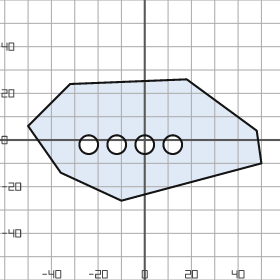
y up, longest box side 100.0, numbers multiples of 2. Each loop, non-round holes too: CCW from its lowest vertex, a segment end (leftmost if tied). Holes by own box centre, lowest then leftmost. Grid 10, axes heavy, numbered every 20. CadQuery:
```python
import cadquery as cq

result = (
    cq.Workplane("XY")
    .moveTo(-10.0, -26.0)
    .lineTo(50.0, -10.0)
    .lineTo(48.0, 4.0)
    .lineTo(18.0, 26.0)
    .lineTo(-32.0, 24.0)
    .lineTo(-50.0, 6.0)
    .lineTo(-36.0, -14.0)
    .close()
    .moveTo(-24.0, -2.0)
    .circle(4.0)
    .moveTo(-12.0, -2.0)
    .circle(4.0)
    .moveTo(0.0, -2.0)
    .circle(4.0)
    .moveTo(12.0, -2.0)
    .circle(4.0)
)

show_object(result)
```